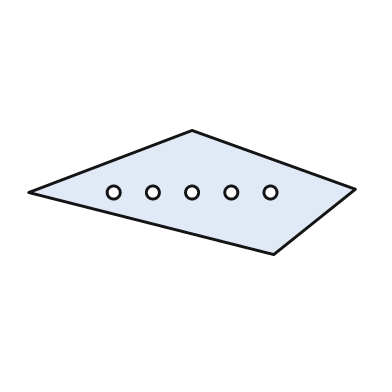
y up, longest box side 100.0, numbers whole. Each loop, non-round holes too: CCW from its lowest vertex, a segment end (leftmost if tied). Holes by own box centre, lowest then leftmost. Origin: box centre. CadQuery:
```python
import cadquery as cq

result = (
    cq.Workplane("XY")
    .moveTo(25.0, -19.0)
    .lineTo(50.0, 1.0)
    .lineTo(0.0, 19.0)
    .lineTo(-50.0, 0.0)
    .close()
    .moveTo(-24.0, 0.0)
    .circle(2.0)
    .moveTo(-12.0, 0.0)
    .circle(2.0)
    .moveTo(0.0, 0.0)
    .circle(2.0)
    .moveTo(12.0, 0.0)
    .circle(2.0)
    .moveTo(24.0, 0.0)
    .circle(2.0)
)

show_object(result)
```